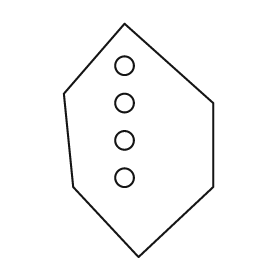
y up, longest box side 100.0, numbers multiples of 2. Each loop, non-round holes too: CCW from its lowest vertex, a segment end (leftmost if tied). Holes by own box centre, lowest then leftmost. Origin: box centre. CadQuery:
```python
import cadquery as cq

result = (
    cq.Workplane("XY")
    .moveTo(0.0, -50.0)
    .lineTo(32.0, -20.0)
    .lineTo(32.0, 16.0)
    .lineTo(-6.0, 50.0)
    .lineTo(-32.0, 20.0)
    .lineTo(-28.0, -20.0)
    .close()
    .moveTo(-6.0, -16.0)
    .circle(4.0)
    .moveTo(-6.0, 0.0)
    .circle(4.0)
    .moveTo(-6.0, 16.0)
    .circle(4.0)
    .moveTo(-6.0, 32.0)
    .circle(4.0)
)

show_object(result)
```